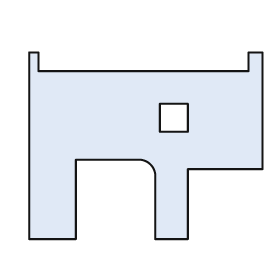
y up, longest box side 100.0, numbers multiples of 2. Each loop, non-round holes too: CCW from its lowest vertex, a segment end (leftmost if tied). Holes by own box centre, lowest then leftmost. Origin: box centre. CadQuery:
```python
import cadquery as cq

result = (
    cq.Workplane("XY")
    .moveTo(-50.0, -40.0)
    .lineTo(-30.0, -40.0)
    .lineTo(-30.0, -6.0)
    .lineTo(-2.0, -6.0)
    .threePointArc((2.0, -8.0), (4.0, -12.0))
    .lineTo(4.0, -40.0)
    .lineTo(18.0, -40.0)
    .lineTo(18.0, -10.0)
    .lineTo(50.0, -10.0)
    .lineTo(50.0, 40.0)
    .lineTo(44.0, 40.0)
    .lineTo(44.0, 32.0)
    .lineTo(-46.0, 32.0)
    .lineTo(-46.0, 40.0)
    .lineTo(-50.0, 40.0)
    .close()
    .moveTo(6.0, 6.0)
    .lineTo(18.0, 6.0)
    .lineTo(18.0, 18.0)
    .lineTo(6.0, 18.0)
    .close()
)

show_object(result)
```